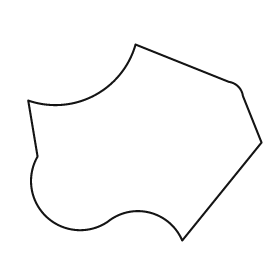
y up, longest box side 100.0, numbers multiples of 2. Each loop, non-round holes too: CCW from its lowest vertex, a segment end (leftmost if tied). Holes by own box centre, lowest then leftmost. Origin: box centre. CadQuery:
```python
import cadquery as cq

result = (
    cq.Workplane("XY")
    .moveTo(16.0, -42.0)
    .lineTo(50.0, 0.0)
    .lineTo(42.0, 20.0)
    .threePointArc((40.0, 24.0), (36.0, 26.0))
    .lineTo(-4.0, 42.0)
    .threePointArc((-22.0, 20.0), (-50.0, 18.0))
    .lineTo(-46.0, -6.0)
    .threePointArc((-42.0, -32.0), (-16.0, -34.0))
    .threePointArc((2.0, -30.0), (16.0, -42.0))
    .close()
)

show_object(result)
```